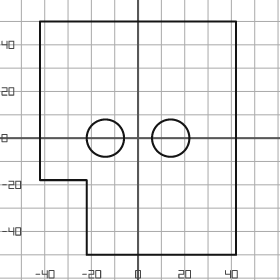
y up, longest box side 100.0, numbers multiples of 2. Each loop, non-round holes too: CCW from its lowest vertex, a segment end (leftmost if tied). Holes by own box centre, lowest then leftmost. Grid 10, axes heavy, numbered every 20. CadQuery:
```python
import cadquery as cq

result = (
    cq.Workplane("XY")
    .moveTo(-22.0, -50.0)
    .lineTo(42.0, -50.0)
    .lineTo(42.0, 50.0)
    .lineTo(-42.0, 50.0)
    .lineTo(-42.0, -18.0)
    .lineTo(-22.0, -18.0)
    .close()
    .moveTo(-14.0, 0.0)
    .circle(8.0)
    .moveTo(14.0, 0.0)
    .circle(8.0)
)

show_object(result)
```